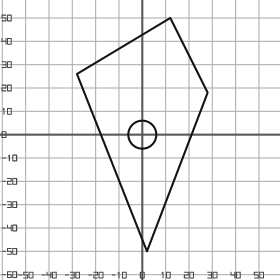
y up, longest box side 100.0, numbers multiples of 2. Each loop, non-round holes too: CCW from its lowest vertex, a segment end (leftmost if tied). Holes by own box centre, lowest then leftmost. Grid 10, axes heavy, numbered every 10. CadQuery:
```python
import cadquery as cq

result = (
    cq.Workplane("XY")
    .moveTo(2.0, -50.0)
    .lineTo(28.0, 18.0)
    .lineTo(12.0, 50.0)
    .lineTo(-28.0, 26.0)
    .close()
    .moveTo(0.0, 0.0)
    .circle(6.0)
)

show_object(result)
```